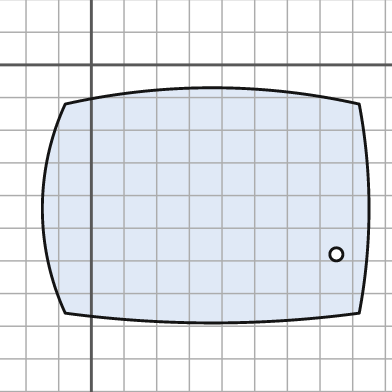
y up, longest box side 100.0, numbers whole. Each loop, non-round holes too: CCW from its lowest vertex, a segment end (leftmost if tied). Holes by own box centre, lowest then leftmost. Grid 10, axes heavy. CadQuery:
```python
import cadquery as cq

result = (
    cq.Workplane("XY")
    .moveTo(-8.0, -76.0)
    .threePointArc((37.0, -79.0), (82.0, -76.0))
    .threePointArc((85.0, -44.0), (82.0, -12.0))
    .threePointArc((37.0, -7.0), (-8.0, -12.0))
    .threePointArc((-15.0, -44.0), (-8.0, -76.0))
    .close()
    .moveTo(75.0, -58.0)
    .circle(2.0)
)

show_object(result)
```